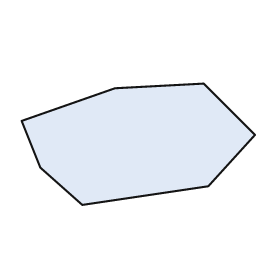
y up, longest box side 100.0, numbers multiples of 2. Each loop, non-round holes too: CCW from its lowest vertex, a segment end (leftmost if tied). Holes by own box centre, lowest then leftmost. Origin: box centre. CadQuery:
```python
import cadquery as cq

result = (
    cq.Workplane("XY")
    .moveTo(-24.0, -26.0)
    .lineTo(30.0, -18.0)
    .lineTo(50.0, 4.0)
    .lineTo(28.0, 26.0)
    .lineTo(-10.0, 24.0)
    .lineTo(-50.0, 10.0)
    .lineTo(-42.0, -10.0)
    .close()
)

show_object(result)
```